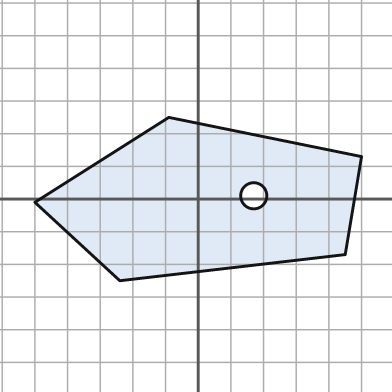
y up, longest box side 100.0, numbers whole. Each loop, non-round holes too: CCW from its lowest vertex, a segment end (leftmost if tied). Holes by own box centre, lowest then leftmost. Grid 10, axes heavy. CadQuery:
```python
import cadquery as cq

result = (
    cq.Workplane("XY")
    .moveTo(-24.0, -25.0)
    .lineTo(45.0, -17.0)
    .lineTo(50.0, 13.0)
    .lineTo(-9.0, 25.0)
    .lineTo(-50.0, -1.0)
    .close()
    .moveTo(17.0, 1.0)
    .circle(4.0)
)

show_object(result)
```